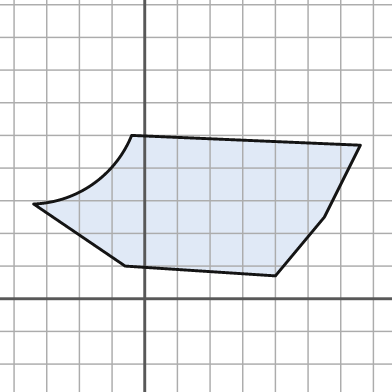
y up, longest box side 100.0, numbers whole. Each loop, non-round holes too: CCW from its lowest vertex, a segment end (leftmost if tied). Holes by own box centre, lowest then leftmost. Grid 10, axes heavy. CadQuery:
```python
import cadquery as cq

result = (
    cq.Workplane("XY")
    .moveTo(40.0, 7.0)
    .lineTo(55.0, 25.0)
    .lineTo(66.0, 47.0)
    .lineTo(-4.0, 50.0)
    .threePointArc((-16.0, 35.0), (-34.0, 29.0))
    .lineTo(-6.0, 10.0)
    .close()
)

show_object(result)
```